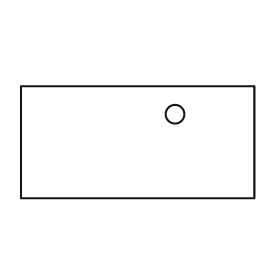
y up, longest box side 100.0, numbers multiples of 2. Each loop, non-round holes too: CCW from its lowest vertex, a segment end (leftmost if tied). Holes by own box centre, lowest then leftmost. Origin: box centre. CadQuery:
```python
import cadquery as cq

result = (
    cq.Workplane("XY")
    .moveTo(-50.0, -24.0)
    .lineTo(50.0, -24.0)
    .lineTo(50.0, 24.0)
    .lineTo(-50.0, 24.0)
    .close()
    .moveTo(16.0, 12.0)
    .circle(4.0)
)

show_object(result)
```